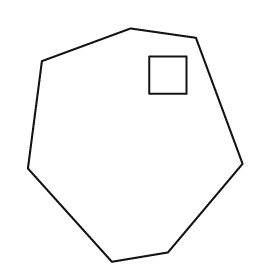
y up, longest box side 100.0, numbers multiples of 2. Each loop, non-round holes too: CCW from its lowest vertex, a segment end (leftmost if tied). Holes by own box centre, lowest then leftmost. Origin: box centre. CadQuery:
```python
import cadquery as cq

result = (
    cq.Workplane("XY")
    .moveTo(-10.0, -50.0)
    .lineTo(14.0, -46.0)
    .lineTo(46.0, -8.0)
    .lineTo(26.0, 46.0)
    .lineTo(-2.0, 50.0)
    .lineTo(-40.0, 36.0)
    .lineTo(-46.0, -10.0)
    .close()
    .moveTo(6.0, 22.0)
    .lineTo(22.0, 22.0)
    .lineTo(22.0, 38.0)
    .lineTo(6.0, 38.0)
    .close()
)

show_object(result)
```